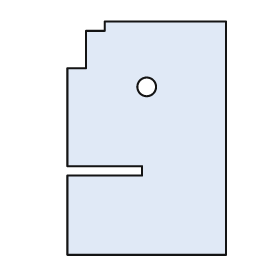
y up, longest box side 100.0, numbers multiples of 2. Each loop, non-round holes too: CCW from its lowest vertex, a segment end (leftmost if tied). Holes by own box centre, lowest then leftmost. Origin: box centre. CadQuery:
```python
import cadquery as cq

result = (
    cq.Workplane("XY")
    .moveTo(-34.0, -50.0)
    .lineTo(34.0, -50.0)
    .lineTo(34.0, 50.0)
    .lineTo(-18.0, 50.0)
    .lineTo(-18.0, 46.0)
    .lineTo(-26.0, 46.0)
    .lineTo(-26.0, 30.0)
    .lineTo(-34.0, 30.0)
    .lineTo(-34.0, -12.0)
    .lineTo(-2.0, -12.0)
    .lineTo(-2.0, -16.0)
    .lineTo(-34.0, -16.0)
    .close()
    .moveTo(0.0, 22.0)
    .circle(4.0)
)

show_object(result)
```